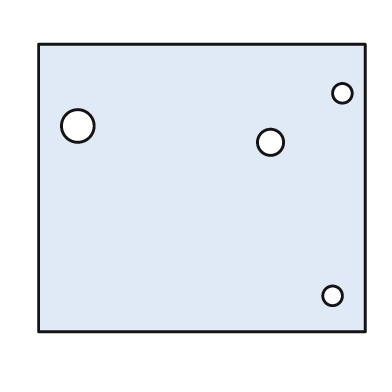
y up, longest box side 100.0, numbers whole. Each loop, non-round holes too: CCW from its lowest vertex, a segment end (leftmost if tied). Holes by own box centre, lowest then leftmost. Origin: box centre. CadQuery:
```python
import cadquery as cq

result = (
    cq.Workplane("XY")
    .moveTo(-50.0, -44.0)
    .lineTo(50.0, -44.0)
    .lineTo(50.0, 44.0)
    .lineTo(-50.0, 44.0)
    .close()
    .moveTo(40.0, -33.0)
    .circle(3.0)
    .moveTo(21.0, 14.0)
    .circle(4.0)
    .moveTo(-38.0, 19.0)
    .circle(5.0)
    .moveTo(43.0, 29.0)
    .circle(3.0)
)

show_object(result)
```